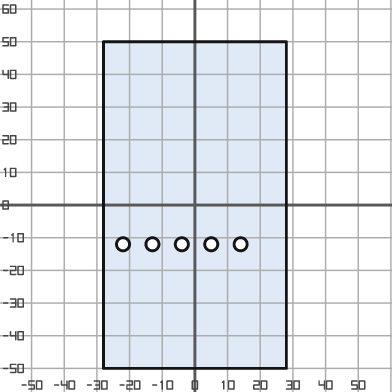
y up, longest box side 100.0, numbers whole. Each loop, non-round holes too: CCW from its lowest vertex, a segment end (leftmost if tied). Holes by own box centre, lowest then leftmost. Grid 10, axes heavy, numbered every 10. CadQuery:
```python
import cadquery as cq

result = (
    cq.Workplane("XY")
    .moveTo(-28.0, -50.0)
    .lineTo(28.0, -50.0)
    .lineTo(28.0, 50.0)
    .lineTo(-28.0, 50.0)
    .close()
    .moveTo(-22.0, -12.0)
    .circle(2.0)
    .moveTo(-13.0, -12.0)
    .circle(2.0)
    .moveTo(-4.0, -12.0)
    .circle(2.0)
    .moveTo(5.0, -12.0)
    .circle(2.0)
    .moveTo(14.0, -12.0)
    .circle(2.0)
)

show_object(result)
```